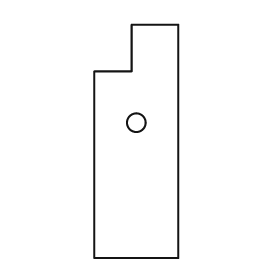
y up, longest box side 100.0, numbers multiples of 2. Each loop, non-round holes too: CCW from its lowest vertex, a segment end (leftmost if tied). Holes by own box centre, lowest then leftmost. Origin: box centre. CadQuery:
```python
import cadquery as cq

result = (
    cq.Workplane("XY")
    .moveTo(-18.0, -50.0)
    .lineTo(18.0, -50.0)
    .lineTo(18.0, 50.0)
    .lineTo(-2.0, 50.0)
    .lineTo(-2.0, 30.0)
    .lineTo(-18.0, 30.0)
    .close()
    .moveTo(0.0, 8.0)
    .circle(4.0)
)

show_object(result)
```